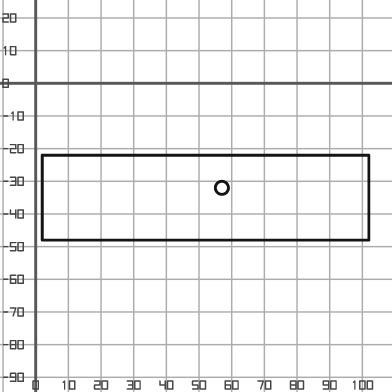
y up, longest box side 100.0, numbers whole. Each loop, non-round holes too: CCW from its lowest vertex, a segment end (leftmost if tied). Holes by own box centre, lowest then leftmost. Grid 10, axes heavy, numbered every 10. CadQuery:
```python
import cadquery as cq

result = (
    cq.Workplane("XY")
    .moveTo(2.0, -48.0)
    .lineTo(102.0, -48.0)
    .lineTo(102.0, -22.0)
    .lineTo(2.0, -22.0)
    .close()
    .moveTo(57.0, -32.0)
    .circle(2.0)
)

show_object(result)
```